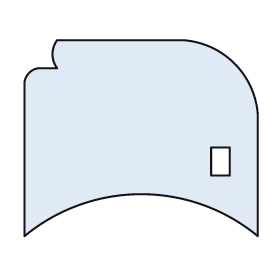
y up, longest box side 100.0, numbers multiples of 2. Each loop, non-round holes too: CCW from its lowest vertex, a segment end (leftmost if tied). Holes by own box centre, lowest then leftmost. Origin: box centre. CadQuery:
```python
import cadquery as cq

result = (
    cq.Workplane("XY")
    .moveTo(-50.0, -42.0)
    .threePointArc((0.0, -24.0), (50.0, -42.0))
    .lineTo(50.0, 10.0)
    .threePointArc((40.0, 32.0), (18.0, 42.0))
    .lineTo(-36.0, 42.0)
    .threePointArc((-38.0, 36.0), (-36.0, 30.0))
    .lineTo(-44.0, 30.0)
    .threePointArc((-48.0, 28.0), (-50.0, 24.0))
    .close()
    .moveTo(30.0, -16.0)
    .lineTo(38.0, -16.0)
    .lineTo(38.0, -4.0)
    .lineTo(30.0, -4.0)
    .close()
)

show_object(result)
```